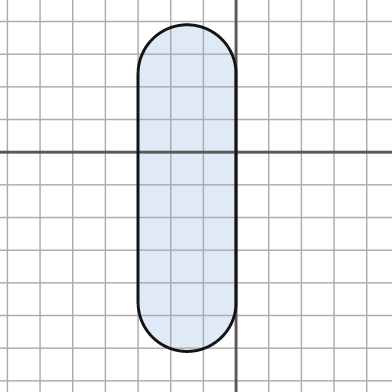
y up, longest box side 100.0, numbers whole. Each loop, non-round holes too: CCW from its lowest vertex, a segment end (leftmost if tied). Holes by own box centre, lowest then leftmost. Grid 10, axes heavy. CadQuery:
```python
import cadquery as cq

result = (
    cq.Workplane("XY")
    .moveTo(-30.0, -46.0)
    .threePointArc((-15.0, -61.0), (0.0, -46.0))
    .lineTo(0.0, 24.0)
    .threePointArc((-15.0, 39.0), (-30.0, 24.0))
    .close()
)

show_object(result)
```